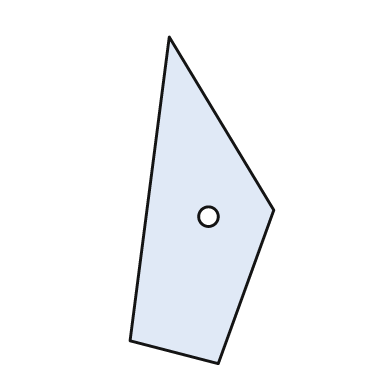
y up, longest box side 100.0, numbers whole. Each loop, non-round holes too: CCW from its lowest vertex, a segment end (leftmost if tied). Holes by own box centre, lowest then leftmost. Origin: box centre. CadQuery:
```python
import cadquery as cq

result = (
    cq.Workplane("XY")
    .moveTo(5.0, -50.0)
    .lineTo(22.0, -3.0)
    .lineTo(-10.0, 50.0)
    .lineTo(-22.0, -43.0)
    .close()
    .moveTo(2.0, -5.0)
    .circle(3.0)
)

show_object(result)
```